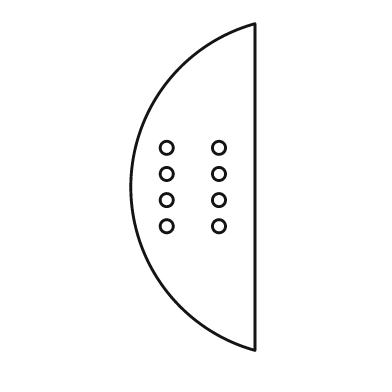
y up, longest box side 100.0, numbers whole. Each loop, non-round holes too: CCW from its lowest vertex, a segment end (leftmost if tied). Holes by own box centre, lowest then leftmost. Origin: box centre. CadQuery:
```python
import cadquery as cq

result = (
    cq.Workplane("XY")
    .moveTo(19.0, -50.0)
    .lineTo(19.0, 50.0)
    .threePointArc((-19.0, 0.0), (19.0, -50.0))
    .close()
    .moveTo(-8.0, -12.0)
    .circle(2.0)
    .moveTo(8.0, -12.0)
    .circle(2.0)
    .moveTo(-8.0, -4.0)
    .circle(2.0)
    .moveTo(8.0, -4.0)
    .circle(2.0)
    .moveTo(-8.0, 4.0)
    .circle(2.0)
    .moveTo(8.0, 4.0)
    .circle(2.0)
    .moveTo(-8.0, 12.0)
    .circle(2.0)
    .moveTo(8.0, 12.0)
    .circle(2.0)
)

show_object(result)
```